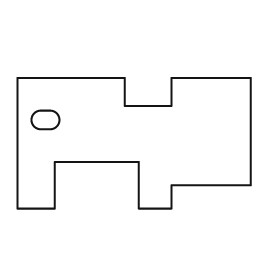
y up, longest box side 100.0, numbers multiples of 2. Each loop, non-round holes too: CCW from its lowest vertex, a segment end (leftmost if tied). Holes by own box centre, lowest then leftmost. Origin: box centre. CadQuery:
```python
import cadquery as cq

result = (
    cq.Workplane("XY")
    .moveTo(-50.0, -28.0)
    .lineTo(-34.0, -28.0)
    .lineTo(-34.0, -8.0)
    .lineTo(2.0, -8.0)
    .lineTo(2.0, -28.0)
    .lineTo(16.0, -28.0)
    .lineTo(16.0, -18.0)
    .lineTo(50.0, -18.0)
    .lineTo(50.0, 28.0)
    .lineTo(16.0, 28.0)
    .lineTo(16.0, 16.0)
    .lineTo(-4.0, 16.0)
    .lineTo(-4.0, 28.0)
    .lineTo(-50.0, 28.0)
    .close()
    .moveTo(-40.0, 6.0)
    .lineTo(-36.0, 6.0)
    .threePointArc((-32.0, 10.0), (-36.0, 14.0))
    .lineTo(-40.0, 14.0)
    .threePointArc((-44.0, 10.0), (-40.0, 6.0))
    .close()
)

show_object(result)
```